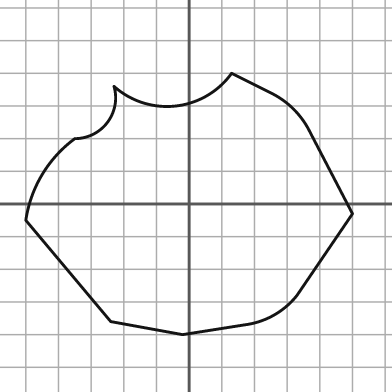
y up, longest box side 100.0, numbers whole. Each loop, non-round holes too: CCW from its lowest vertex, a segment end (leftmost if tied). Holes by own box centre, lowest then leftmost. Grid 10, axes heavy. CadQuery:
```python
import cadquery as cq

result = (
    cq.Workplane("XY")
    .moveTo(-2.0, -40.0)
    .lineTo(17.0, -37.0)
    .threePointArc((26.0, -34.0), (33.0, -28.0))
    .lineTo(50.0, -3.0)
    .lineTo(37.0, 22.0)
    .threePointArc((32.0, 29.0), (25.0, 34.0))
    .lineTo(13.0, 40.0)
    .threePointArc((-4.0, 30.0), (-23.0, 36.0))
    .threePointArc((-25.0, 25.0), (-35.0, 20.0))
    .threePointArc((-45.0, 9.0), (-50.0, -5.0))
    .lineTo(-24.0, -36.0)
    .close()
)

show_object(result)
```